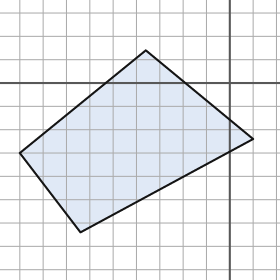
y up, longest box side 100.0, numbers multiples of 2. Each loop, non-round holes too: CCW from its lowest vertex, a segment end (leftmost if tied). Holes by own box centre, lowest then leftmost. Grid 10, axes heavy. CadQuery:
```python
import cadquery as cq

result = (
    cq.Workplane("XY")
    .moveTo(-64.0, -64.0)
    .lineTo(10.0, -24.0)
    .lineTo(-36.0, 14.0)
    .lineTo(-90.0, -30.0)
    .close()
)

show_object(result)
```